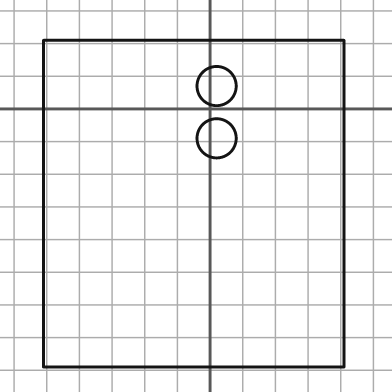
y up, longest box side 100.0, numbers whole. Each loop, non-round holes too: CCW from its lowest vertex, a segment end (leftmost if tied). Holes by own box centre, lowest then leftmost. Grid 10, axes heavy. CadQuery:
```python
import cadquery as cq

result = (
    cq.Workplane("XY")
    .moveTo(-51.0, -79.0)
    .lineTo(41.0, -79.0)
    .lineTo(41.0, 21.0)
    .lineTo(-51.0, 21.0)
    .close()
    .moveTo(2.0, -9.0)
    .circle(6.0)
    .moveTo(2.0, 7.0)
    .circle(6.0)
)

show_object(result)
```